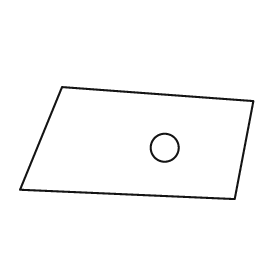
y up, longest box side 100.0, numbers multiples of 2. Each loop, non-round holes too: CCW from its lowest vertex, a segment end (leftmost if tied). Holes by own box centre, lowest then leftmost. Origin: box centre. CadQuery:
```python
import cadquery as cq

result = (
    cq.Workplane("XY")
    .moveTo(42.0, -24.0)
    .lineTo(50.0, 18.0)
    .lineTo(-32.0, 24.0)
    .lineTo(-50.0, -20.0)
    .close()
    .moveTo(12.0, -2.0)
    .circle(6.0)
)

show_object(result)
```